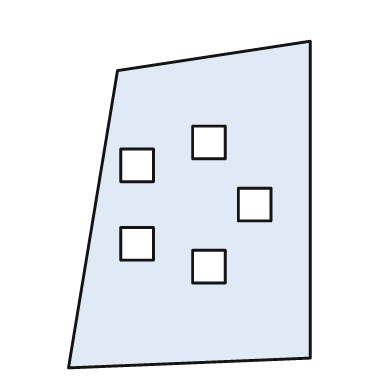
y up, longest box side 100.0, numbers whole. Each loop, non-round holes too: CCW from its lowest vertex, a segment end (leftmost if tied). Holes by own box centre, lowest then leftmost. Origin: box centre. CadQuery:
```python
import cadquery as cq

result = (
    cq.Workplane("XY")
    .moveTo(-37.0, -50.0)
    .lineTo(37.0, -47.0)
    .lineTo(37.0, 50.0)
    .lineTo(-22.0, 41.0)
    .close()
    .moveTo(1.0, -24.0)
    .lineTo(11.0, -24.0)
    .lineTo(11.0, -14.0)
    .lineTo(1.0, -14.0)
    .close()
    .moveTo(-21.0, -17.0)
    .lineTo(-11.0, -17.0)
    .lineTo(-11.0, -7.0)
    .lineTo(-21.0, -7.0)
    .close()
    .moveTo(15.0, -5.0)
    .lineTo(25.0, -5.0)
    .lineTo(25.0, 5.0)
    .lineTo(15.0, 5.0)
    .close()
    .moveTo(-21.0, 7.0)
    .lineTo(-11.0, 7.0)
    .lineTo(-11.0, 17.0)
    .lineTo(-21.0, 17.0)
    .close()
    .moveTo(1.0, 14.0)
    .lineTo(11.0, 14.0)
    .lineTo(11.0, 24.0)
    .lineTo(1.0, 24.0)
    .close()
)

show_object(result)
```